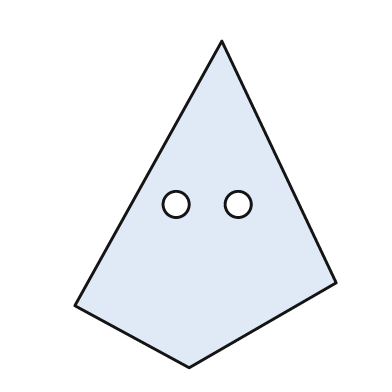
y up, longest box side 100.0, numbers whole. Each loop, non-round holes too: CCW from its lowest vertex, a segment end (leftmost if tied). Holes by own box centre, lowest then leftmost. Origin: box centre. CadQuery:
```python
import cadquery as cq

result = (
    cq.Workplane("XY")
    .moveTo(-5.0, -50.0)
    .lineTo(40.0, -24.0)
    .lineTo(5.0, 50.0)
    .lineTo(-40.0, -31.0)
    .close()
    .moveTo(-9.0, 0.0)
    .circle(4.0)
    .moveTo(10.0, 0.0)
    .circle(4.0)
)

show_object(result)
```